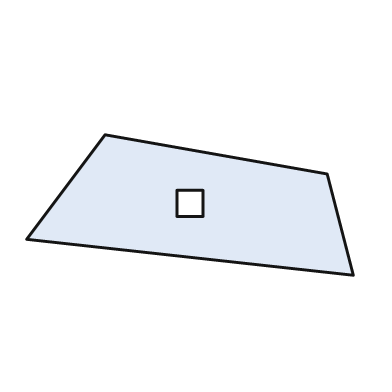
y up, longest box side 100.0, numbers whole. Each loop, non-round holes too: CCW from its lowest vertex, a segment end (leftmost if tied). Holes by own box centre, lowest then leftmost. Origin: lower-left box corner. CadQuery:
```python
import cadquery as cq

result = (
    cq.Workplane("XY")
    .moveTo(100.0, 0.0)
    .lineTo(92.0, 31.0)
    .lineTo(24.0, 43.0)
    .lineTo(0.0, 11.0)
    .close()
    .moveTo(46.0, 18.0)
    .lineTo(54.0, 18.0)
    .lineTo(54.0, 26.0)
    .lineTo(46.0, 26.0)
    .close()
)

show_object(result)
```